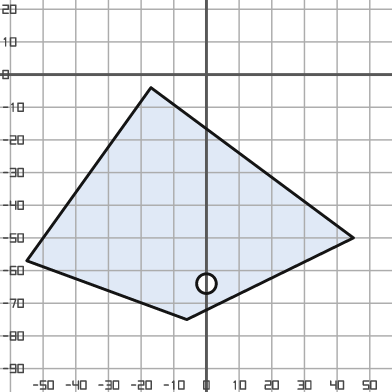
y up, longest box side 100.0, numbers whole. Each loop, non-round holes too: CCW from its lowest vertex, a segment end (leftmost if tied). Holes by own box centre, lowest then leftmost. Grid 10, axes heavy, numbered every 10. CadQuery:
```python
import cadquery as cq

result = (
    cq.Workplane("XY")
    .moveTo(-6.0, -75.0)
    .lineTo(45.0, -50.0)
    .lineTo(-17.0, -4.0)
    .lineTo(-55.0, -57.0)
    .close()
    .moveTo(0.0, -64.0)
    .circle(3.0)
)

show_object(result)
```